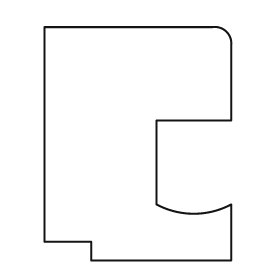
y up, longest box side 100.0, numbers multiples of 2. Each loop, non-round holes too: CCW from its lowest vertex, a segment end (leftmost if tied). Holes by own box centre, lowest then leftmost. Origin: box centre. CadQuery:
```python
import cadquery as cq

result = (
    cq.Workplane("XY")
    .moveTo(-20.0, -50.0)
    .lineTo(40.0, -50.0)
    .lineTo(40.0, -26.0)
    .threePointArc((24.0, -30.0), (8.0, -26.0))
    .lineTo(8.0, 10.0)
    .lineTo(40.0, 10.0)
    .lineTo(40.0, 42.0)
    .threePointArc((38.0, 48.0), (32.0, 50.0))
    .lineTo(-40.0, 50.0)
    .lineTo(-40.0, -42.0)
    .lineTo(-20.0, -42.0)
    .close()
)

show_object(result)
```